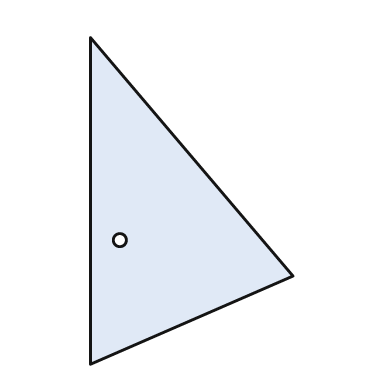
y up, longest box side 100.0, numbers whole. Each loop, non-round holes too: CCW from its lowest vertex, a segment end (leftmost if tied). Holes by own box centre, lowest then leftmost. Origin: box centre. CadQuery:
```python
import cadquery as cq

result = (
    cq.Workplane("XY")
    .moveTo(-31.0, -50.0)
    .lineTo(31.0, -23.0)
    .lineTo(-31.0, 50.0)
    .close()
    .moveTo(-22.0, -12.0)
    .circle(2.0)
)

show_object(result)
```